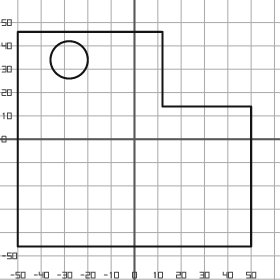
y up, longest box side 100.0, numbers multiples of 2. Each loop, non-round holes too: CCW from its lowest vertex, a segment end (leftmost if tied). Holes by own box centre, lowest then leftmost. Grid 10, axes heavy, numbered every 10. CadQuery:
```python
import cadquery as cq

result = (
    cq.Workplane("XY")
    .moveTo(-50.0, -46.0)
    .lineTo(50.0, -46.0)
    .lineTo(50.0, 14.0)
    .lineTo(12.0, 14.0)
    .lineTo(12.0, 46.0)
    .lineTo(-50.0, 46.0)
    .close()
    .moveTo(-28.0, 34.0)
    .circle(8.0)
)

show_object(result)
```